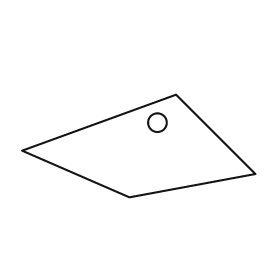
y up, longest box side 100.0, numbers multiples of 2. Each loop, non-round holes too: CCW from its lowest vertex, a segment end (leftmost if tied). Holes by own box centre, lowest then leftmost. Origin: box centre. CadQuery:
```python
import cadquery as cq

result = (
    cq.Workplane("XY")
    .moveTo(-4.0, -22.0)
    .lineTo(50.0, -12.0)
    .lineTo(16.0, 22.0)
    .lineTo(-50.0, -2.0)
    .close()
    .moveTo(8.0, 10.0)
    .circle(4.0)
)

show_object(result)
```